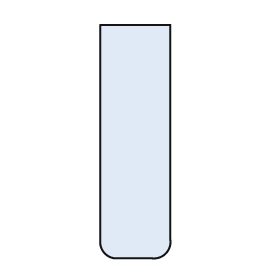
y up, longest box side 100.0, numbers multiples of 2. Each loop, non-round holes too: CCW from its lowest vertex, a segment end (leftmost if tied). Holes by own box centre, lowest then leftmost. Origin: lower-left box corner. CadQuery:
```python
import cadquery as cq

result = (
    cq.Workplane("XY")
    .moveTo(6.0, 0.0)
    .lineTo(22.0, 0.0)
    .threePointArc((28.0, 2.0), (30.0, 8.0))
    .lineTo(30.0, 100.0)
    .lineTo(0.0, 100.0)
    .lineTo(0.0, 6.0)
    .threePointArc((2.0, 2.0), (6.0, 0.0))
    .close()
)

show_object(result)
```